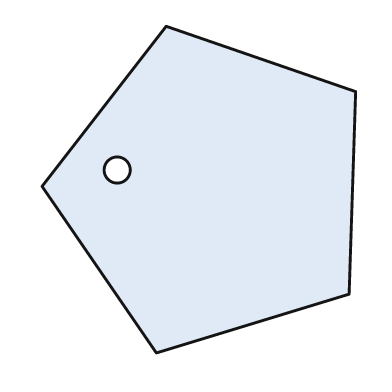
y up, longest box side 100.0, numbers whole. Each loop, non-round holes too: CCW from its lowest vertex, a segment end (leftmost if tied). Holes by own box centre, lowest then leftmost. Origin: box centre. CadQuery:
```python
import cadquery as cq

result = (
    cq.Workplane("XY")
    .moveTo(-13.0, -50.0)
    .lineTo(46.0, -32.0)
    .lineTo(48.0, 30.0)
    .lineTo(-10.0, 50.0)
    .lineTo(-48.0, 1.0)
    .close()
    .moveTo(-25.0, 6.0)
    .circle(4.0)
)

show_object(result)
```